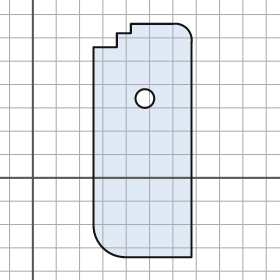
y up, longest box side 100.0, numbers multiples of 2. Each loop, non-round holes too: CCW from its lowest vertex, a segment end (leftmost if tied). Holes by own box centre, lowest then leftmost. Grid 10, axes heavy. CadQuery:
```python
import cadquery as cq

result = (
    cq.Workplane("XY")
    .moveTo(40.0, -34.0)
    .lineTo(68.0, -34.0)
    .lineTo(68.0, 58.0)
    .threePointArc((66.0, 64.0), (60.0, 66.0))
    .lineTo(42.0, 66.0)
    .lineTo(42.0, 62.0)
    .lineTo(36.0, 62.0)
    .lineTo(36.0, 56.0)
    .lineTo(26.0, 56.0)
    .lineTo(26.0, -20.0)
    .threePointArc((30.0, -30.0), (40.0, -34.0))
    .close()
    .moveTo(48.0, 34.0)
    .circle(4.0)
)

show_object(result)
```